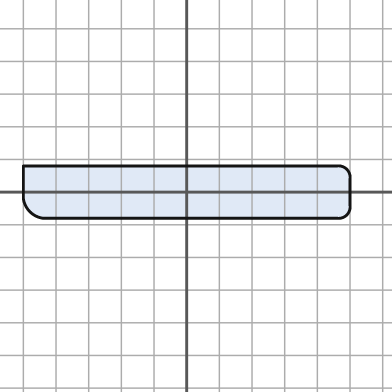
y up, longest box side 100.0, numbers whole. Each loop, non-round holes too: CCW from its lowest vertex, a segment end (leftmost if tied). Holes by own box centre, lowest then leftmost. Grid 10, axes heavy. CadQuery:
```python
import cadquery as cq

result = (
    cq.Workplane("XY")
    .moveTo(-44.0, -8.0)
    .lineTo(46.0, -8.0)
    .threePointArc((49.0, -7.0), (50.0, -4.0))
    .lineTo(50.0, 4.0)
    .threePointArc((49.0, 7.0), (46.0, 8.0))
    .lineTo(-50.0, 8.0)
    .lineTo(-50.0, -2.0)
    .threePointArc((-48.0, -6.0), (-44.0, -8.0))
    .close()
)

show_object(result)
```